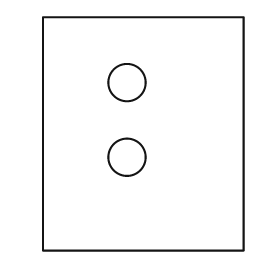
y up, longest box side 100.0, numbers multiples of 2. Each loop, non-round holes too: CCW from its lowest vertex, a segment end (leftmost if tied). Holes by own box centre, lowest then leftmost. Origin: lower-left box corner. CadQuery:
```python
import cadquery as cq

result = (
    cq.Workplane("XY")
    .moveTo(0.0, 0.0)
    .lineTo(86.0, 0.0)
    .lineTo(86.0, 100.0)
    .lineTo(0.0, 100.0)
    .close()
    .moveTo(36.0, 40.0)
    .circle(8.0)
    .moveTo(36.0, 72.0)
    .circle(8.0)
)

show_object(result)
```